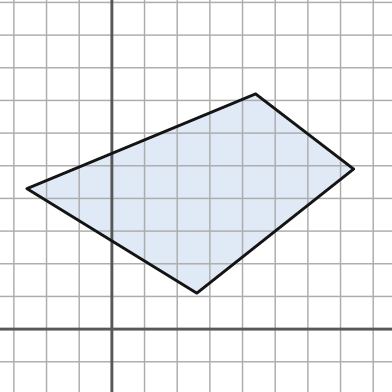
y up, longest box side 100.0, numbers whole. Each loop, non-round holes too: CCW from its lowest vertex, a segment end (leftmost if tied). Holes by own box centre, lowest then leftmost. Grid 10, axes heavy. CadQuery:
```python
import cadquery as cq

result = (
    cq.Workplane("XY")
    .moveTo(26.0, 11.0)
    .lineTo(74.0, 49.0)
    .lineTo(44.0, 72.0)
    .lineTo(-26.0, 43.0)
    .close()
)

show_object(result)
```